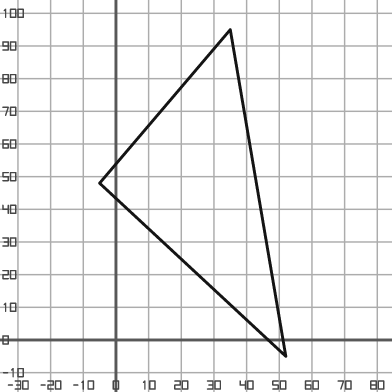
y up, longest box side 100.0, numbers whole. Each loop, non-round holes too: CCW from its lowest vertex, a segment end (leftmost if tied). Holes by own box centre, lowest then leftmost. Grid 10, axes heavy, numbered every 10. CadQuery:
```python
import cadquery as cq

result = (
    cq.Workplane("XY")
    .moveTo(52.0, -5.0)
    .lineTo(35.0, 95.0)
    .lineTo(-5.0, 48.0)
    .close()
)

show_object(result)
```